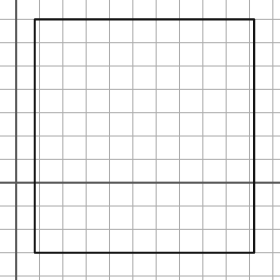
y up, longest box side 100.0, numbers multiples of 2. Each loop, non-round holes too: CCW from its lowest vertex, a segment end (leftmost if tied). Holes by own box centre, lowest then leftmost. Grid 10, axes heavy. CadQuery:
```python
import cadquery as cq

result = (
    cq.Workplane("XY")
    .moveTo(8.0, -30.0)
    .lineTo(102.0, -30.0)
    .lineTo(102.0, 70.0)
    .lineTo(8.0, 70.0)
    .close()
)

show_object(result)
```